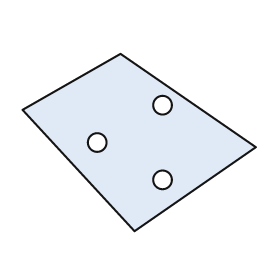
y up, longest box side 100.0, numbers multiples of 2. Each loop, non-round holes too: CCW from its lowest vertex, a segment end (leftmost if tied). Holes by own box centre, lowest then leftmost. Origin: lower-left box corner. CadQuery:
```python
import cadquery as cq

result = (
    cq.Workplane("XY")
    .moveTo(48.0, 0.0)
    .lineTo(100.0, 36.0)
    .lineTo(42.0, 76.0)
    .lineTo(0.0, 52.0)
    .close()
    .moveTo(60.0, 22.0)
    .circle(4.0)
    .moveTo(32.0, 38.0)
    .circle(4.0)
    .moveTo(60.0, 54.0)
    .circle(4.0)
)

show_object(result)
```